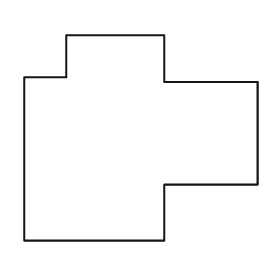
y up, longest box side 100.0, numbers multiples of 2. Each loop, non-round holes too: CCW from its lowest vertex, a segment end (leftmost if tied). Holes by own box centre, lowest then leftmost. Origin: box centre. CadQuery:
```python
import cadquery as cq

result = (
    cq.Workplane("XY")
    .moveTo(-50.0, -44.0)
    .lineTo(10.0, -44.0)
    .lineTo(10.0, -20.0)
    .lineTo(50.0, -20.0)
    .lineTo(50.0, 24.0)
    .lineTo(10.0, 24.0)
    .lineTo(10.0, 44.0)
    .lineTo(-32.0, 44.0)
    .lineTo(-32.0, 26.0)
    .lineTo(-50.0, 26.0)
    .close()
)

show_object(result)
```